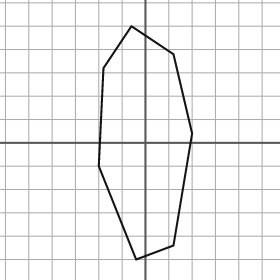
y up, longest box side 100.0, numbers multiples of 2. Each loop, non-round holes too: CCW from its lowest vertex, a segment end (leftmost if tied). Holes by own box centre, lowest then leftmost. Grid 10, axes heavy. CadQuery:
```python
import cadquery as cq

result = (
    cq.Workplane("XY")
    .moveTo(-4.0, -50.0)
    .lineTo(12.0, -44.0)
    .lineTo(20.0, 4.0)
    .lineTo(12.0, 38.0)
    .lineTo(-6.0, 50.0)
    .lineTo(-18.0, 32.0)
    .lineTo(-20.0, -10.0)
    .close()
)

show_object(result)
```